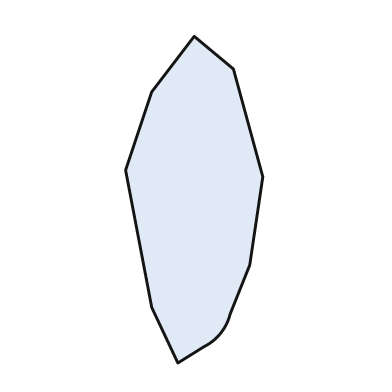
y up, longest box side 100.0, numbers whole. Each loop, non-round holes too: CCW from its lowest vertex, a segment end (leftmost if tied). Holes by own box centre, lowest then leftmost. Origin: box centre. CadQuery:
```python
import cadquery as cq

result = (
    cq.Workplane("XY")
    .moveTo(-5.0, -50.0)
    .lineTo(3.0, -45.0)
    .threePointArc((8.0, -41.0), (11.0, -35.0))
    .lineTo(17.0, -20.0)
    .lineTo(21.0, 7.0)
    .lineTo(12.0, 40.0)
    .lineTo(0.0, 50.0)
    .lineTo(-13.0, 33.0)
    .lineTo(-21.0, 9.0)
    .lineTo(-13.0, -33.0)
    .close()
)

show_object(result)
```